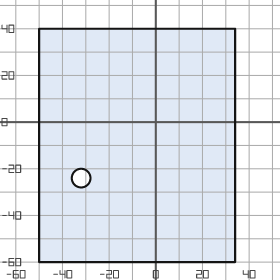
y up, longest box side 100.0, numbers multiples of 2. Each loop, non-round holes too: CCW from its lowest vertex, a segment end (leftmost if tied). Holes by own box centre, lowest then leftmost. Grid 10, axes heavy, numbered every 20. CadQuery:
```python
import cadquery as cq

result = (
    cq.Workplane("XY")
    .moveTo(-50.0, -60.0)
    .lineTo(34.0, -60.0)
    .lineTo(34.0, 40.0)
    .lineTo(-50.0, 40.0)
    .close()
    .moveTo(-32.0, -24.0)
    .circle(4.0)
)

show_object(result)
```